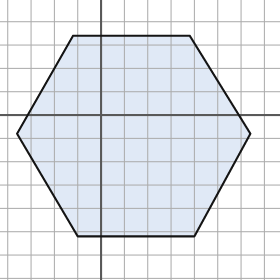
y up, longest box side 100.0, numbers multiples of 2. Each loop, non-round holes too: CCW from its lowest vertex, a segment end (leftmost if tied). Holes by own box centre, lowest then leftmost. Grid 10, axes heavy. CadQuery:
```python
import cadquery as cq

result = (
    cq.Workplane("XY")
    .moveTo(-10.0, -52.0)
    .lineTo(40.0, -52.0)
    .lineTo(64.0, -8.0)
    .lineTo(38.0, 34.0)
    .lineTo(-12.0, 34.0)
    .lineTo(-36.0, -8.0)
    .close()
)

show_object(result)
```